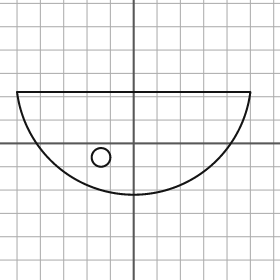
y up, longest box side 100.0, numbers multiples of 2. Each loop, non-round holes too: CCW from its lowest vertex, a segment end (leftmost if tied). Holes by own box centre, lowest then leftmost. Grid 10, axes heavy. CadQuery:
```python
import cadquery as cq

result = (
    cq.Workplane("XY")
    .moveTo(-50.0, 22.0)
    .threePointArc((0.0, -22.0), (50.0, 22.0))
    .close()
    .moveTo(-14.0, -6.0)
    .circle(4.0)
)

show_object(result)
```